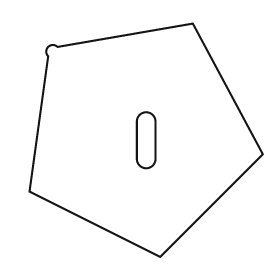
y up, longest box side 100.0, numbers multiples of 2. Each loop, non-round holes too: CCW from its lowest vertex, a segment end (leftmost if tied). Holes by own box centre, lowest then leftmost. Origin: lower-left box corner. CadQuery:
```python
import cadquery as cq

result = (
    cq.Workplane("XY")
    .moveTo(56.0, 0.0)
    .lineTo(100.0, 44.0)
    .lineTo(70.0, 100.0)
    .lineTo(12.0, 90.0)
    .threePointArc((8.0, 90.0), (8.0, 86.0))
    .lineTo(0.0, 28.0)
    .close()
    .moveTo(46.0, 42.0)
    .threePointArc((50.0, 38.0), (54.0, 42.0))
    .lineTo(54.0, 58.0)
    .threePointArc((50.0, 62.0), (46.0, 58.0))
    .close()
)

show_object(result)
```